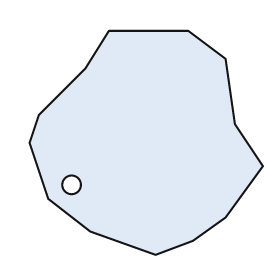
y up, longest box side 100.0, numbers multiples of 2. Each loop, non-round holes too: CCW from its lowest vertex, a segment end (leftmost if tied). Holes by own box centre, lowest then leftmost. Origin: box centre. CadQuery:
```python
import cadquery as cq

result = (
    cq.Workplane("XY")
    .moveTo(4.0, -48.0)
    .lineTo(20.0, -42.0)
    .lineTo(34.0, -32.0)
    .lineTo(50.0, -10.0)
    .lineTo(38.0, 8.0)
    .lineTo(34.0, 36.0)
    .lineTo(18.0, 48.0)
    .lineTo(-16.0, 48.0)
    .lineTo(-26.0, 32.0)
    .lineTo(-46.0, 12.0)
    .lineTo(-50.0, 0.0)
    .lineTo(-42.0, -24.0)
    .lineTo(-24.0, -38.0)
    .close()
    .moveTo(-32.0, -18.0)
    .circle(4.0)
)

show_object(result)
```